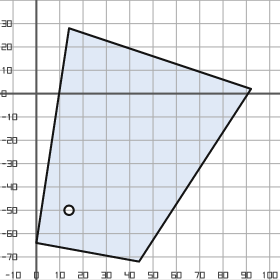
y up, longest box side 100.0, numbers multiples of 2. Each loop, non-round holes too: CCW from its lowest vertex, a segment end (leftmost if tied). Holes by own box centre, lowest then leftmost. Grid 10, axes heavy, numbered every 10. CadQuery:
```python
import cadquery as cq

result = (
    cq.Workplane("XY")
    .moveTo(44.0, -72.0)
    .lineTo(92.0, 2.0)
    .lineTo(14.0, 28.0)
    .lineTo(0.0, -64.0)
    .close()
    .moveTo(14.0, -50.0)
    .circle(2.0)
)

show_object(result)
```